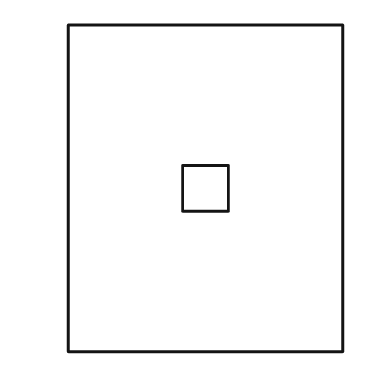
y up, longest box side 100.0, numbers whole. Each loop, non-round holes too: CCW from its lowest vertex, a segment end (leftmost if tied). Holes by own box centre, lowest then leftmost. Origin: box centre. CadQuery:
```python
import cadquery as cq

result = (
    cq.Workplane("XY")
    .moveTo(-42.0, -50.0)
    .lineTo(42.0, -50.0)
    .lineTo(42.0, 50.0)
    .lineTo(-42.0, 50.0)
    .close()
    .moveTo(-7.0, -7.0)
    .lineTo(7.0, -7.0)
    .lineTo(7.0, 7.0)
    .lineTo(-7.0, 7.0)
    .close()
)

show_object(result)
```